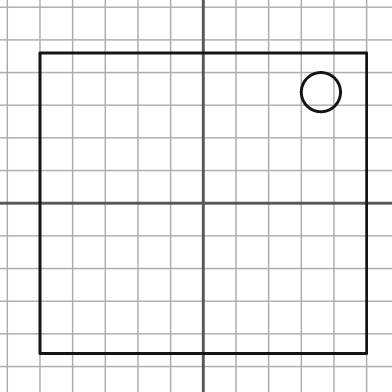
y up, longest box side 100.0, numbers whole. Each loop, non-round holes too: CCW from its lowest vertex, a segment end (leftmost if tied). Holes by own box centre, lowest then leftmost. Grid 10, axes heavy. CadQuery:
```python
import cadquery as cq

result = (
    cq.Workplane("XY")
    .moveTo(-50.0, -46.0)
    .lineTo(50.0, -46.0)
    .lineTo(50.0, 46.0)
    .lineTo(-50.0, 46.0)
    .close()
    .moveTo(36.0, 34.0)
    .circle(6.0)
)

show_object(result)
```